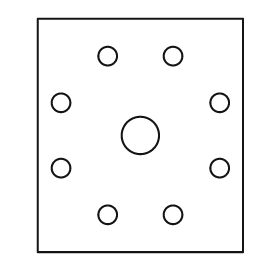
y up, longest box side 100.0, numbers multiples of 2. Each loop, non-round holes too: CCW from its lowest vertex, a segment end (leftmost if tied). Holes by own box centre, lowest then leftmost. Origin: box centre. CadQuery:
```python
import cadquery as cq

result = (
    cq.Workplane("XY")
    .moveTo(-44.0, -50.0)
    .lineTo(44.0, -50.0)
    .lineTo(44.0, 50.0)
    .lineTo(-44.0, 50.0)
    .close()
    .moveTo(-14.0, -34.0)
    .circle(4.0)
    .moveTo(14.0, -34.0)
    .circle(4.0)
    .moveTo(-34.0, -14.0)
    .circle(4.0)
    .moveTo(34.0, -14.0)
    .circle(4.0)
    .moveTo(0.0, 0.0)
    .circle(8.0)
    .moveTo(-34.0, 14.0)
    .circle(4.0)
    .moveTo(34.0, 14.0)
    .circle(4.0)
    .moveTo(-14.0, 34.0)
    .circle(4.0)
    .moveTo(14.0, 34.0)
    .circle(4.0)
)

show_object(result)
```